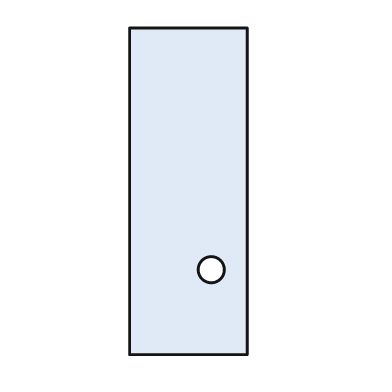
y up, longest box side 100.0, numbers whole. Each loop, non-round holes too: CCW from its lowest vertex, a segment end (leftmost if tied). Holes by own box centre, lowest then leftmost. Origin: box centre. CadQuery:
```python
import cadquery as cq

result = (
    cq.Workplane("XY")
    .moveTo(-18.0, -50.0)
    .lineTo(18.0, -50.0)
    .lineTo(18.0, 50.0)
    .lineTo(-18.0, 50.0)
    .close()
    .moveTo(7.0, -24.0)
    .circle(4.0)
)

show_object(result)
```